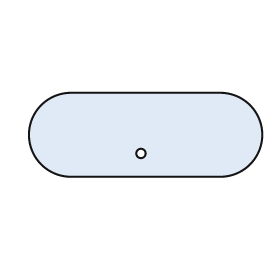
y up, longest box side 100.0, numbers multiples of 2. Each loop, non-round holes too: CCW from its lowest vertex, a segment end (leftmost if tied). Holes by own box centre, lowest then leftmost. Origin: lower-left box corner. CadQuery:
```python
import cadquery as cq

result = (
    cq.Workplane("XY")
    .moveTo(18.0, 0.0)
    .lineTo(82.0, 0.0)
    .threePointArc((100.0, 18.0), (82.0, 36.0))
    .lineTo(18.0, 36.0)
    .threePointArc((0.0, 18.0), (18.0, 0.0))
    .close()
    .moveTo(48.0, 10.0)
    .circle(2.0)
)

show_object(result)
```